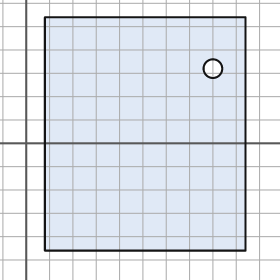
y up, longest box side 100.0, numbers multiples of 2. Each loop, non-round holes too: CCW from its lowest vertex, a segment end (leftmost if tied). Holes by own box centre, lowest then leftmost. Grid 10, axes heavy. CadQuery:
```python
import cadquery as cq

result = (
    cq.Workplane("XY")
    .moveTo(8.0, -46.0)
    .lineTo(94.0, -46.0)
    .lineTo(94.0, 54.0)
    .lineTo(8.0, 54.0)
    .close()
    .moveTo(80.0, 32.0)
    .circle(4.0)
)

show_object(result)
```